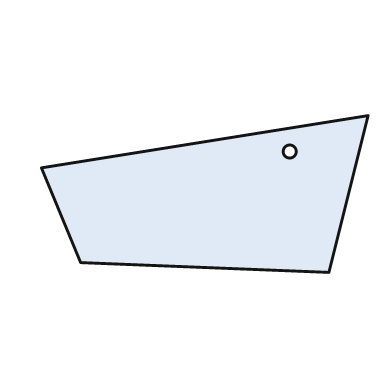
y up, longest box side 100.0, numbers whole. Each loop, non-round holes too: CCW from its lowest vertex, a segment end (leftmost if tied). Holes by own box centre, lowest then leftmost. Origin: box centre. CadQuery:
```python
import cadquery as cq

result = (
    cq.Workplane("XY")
    .moveTo(38.0, -24.0)
    .lineTo(50.0, 24.0)
    .lineTo(-50.0, 8.0)
    .lineTo(-38.0, -21.0)
    .close()
    .moveTo(26.0, 13.0)
    .circle(2.0)
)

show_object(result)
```